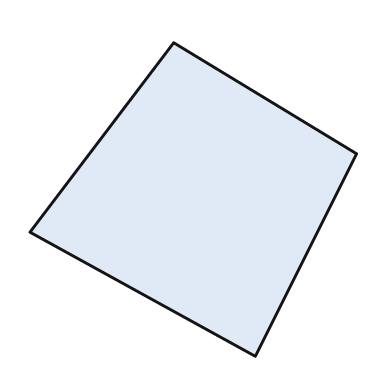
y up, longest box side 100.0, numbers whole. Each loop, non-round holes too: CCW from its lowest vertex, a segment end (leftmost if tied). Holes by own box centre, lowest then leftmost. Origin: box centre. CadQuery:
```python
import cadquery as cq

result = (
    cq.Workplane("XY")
    .moveTo(19.0, -48.0)
    .lineTo(50.0, 14.0)
    .lineTo(-6.0, 48.0)
    .lineTo(-50.0, -10.0)
    .close()
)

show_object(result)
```